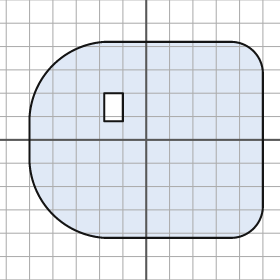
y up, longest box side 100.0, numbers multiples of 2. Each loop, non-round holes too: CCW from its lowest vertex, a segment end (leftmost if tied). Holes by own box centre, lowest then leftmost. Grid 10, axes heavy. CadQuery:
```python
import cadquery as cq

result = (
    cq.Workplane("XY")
    .moveTo(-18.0, -42.0)
    .lineTo(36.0, -42.0)
    .threePointArc((46.0, -38.0), (50.0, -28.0))
    .lineTo(50.0, 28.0)
    .threePointArc((46.0, 38.0), (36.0, 42.0))
    .lineTo(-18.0, 42.0)
    .threePointArc((-40.0, 32.0), (-50.0, 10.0))
    .lineTo(-50.0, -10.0)
    .threePointArc((-40.0, -32.0), (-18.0, -42.0))
    .close()
    .moveTo(-18.0, 8.0)
    .lineTo(-10.0, 8.0)
    .lineTo(-10.0, 20.0)
    .lineTo(-18.0, 20.0)
    .close()
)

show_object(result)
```